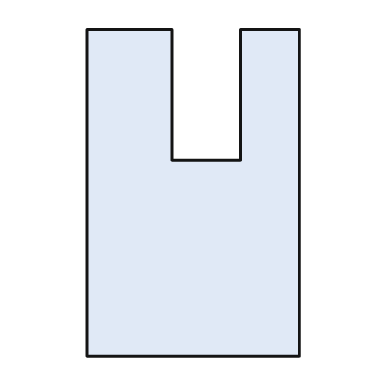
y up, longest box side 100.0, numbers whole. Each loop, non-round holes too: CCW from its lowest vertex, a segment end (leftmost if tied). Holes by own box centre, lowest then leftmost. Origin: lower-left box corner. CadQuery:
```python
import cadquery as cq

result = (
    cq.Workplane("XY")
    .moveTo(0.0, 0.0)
    .lineTo(65.0, 0.0)
    .lineTo(65.0, 100.0)
    .lineTo(47.0, 100.0)
    .lineTo(47.0, 60.0)
    .lineTo(26.0, 60.0)
    .lineTo(26.0, 100.0)
    .lineTo(0.0, 100.0)
    .close()
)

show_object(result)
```